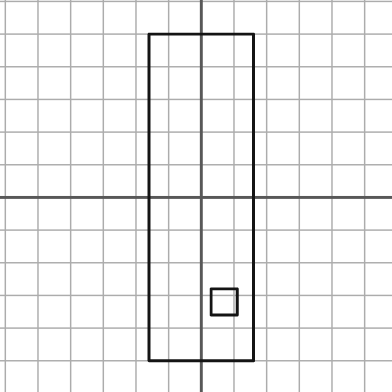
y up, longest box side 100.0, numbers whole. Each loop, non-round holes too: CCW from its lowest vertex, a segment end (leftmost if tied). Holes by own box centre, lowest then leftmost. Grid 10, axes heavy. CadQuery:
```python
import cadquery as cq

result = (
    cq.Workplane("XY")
    .moveTo(-16.0, -50.0)
    .lineTo(16.0, -50.0)
    .lineTo(16.0, 50.0)
    .lineTo(-16.0, 50.0)
    .close()
    .moveTo(3.0, -36.0)
    .lineTo(11.0, -36.0)
    .lineTo(11.0, -28.0)
    .lineTo(3.0, -28.0)
    .close()
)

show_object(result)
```